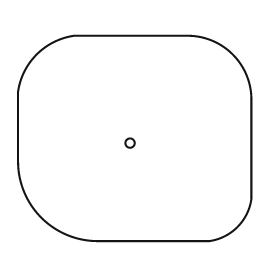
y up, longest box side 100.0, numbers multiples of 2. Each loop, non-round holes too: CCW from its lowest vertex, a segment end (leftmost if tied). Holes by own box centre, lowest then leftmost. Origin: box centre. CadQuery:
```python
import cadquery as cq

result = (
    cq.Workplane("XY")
    .moveTo(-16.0, -44.0)
    .lineTo(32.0, -44.0)
    .threePointArc((44.0, -38.0), (50.0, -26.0))
    .lineTo(50.0, 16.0)
    .threePointArc((42.0, 36.0), (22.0, 44.0))
    .lineTo(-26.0, 44.0)
    .threePointArc((-42.0, 36.0), (-50.0, 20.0))
    .lineTo(-50.0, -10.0)
    .threePointArc((-40.0, -34.0), (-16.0, -44.0))
    .close()
    .moveTo(-2.0, -2.0)
    .circle(2.0)
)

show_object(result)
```